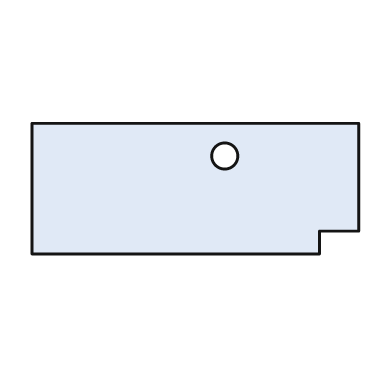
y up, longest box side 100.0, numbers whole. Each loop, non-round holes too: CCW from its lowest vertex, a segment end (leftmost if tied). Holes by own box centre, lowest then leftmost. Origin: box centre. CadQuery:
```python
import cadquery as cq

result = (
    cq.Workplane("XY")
    .moveTo(-50.0, -20.0)
    .lineTo(38.0, -20.0)
    .lineTo(38.0, -13.0)
    .lineTo(50.0, -13.0)
    .lineTo(50.0, 20.0)
    .lineTo(-50.0, 20.0)
    .close()
    .moveTo(9.0, 10.0)
    .circle(4.0)
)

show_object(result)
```